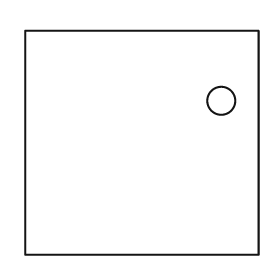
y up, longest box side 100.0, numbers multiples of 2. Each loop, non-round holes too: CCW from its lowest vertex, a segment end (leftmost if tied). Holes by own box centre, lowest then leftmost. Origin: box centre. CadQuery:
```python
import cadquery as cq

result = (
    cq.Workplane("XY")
    .moveTo(-50.0, -48.0)
    .lineTo(50.0, -48.0)
    .lineTo(50.0, 48.0)
    .lineTo(-50.0, 48.0)
    .close()
    .moveTo(34.0, 18.0)
    .circle(6.0)
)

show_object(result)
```